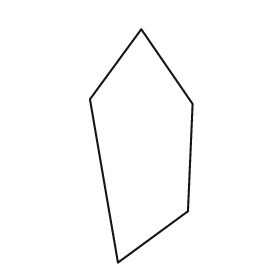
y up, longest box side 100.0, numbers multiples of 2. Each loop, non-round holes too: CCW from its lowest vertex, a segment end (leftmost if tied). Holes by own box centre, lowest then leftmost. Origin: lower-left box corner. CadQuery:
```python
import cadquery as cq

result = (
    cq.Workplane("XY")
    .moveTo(12.0, 0.0)
    .lineTo(42.0, 22.0)
    .lineTo(44.0, 68.0)
    .lineTo(22.0, 100.0)
    .lineTo(0.0, 70.0)
    .close()
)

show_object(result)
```